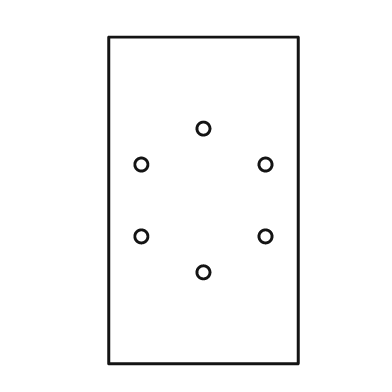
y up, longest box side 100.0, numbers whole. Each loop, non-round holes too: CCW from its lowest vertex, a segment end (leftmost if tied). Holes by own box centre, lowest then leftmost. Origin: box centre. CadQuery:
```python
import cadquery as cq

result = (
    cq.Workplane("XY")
    .moveTo(-29.0, -50.0)
    .lineTo(29.0, -50.0)
    .lineTo(29.0, 50.0)
    .lineTo(-29.0, 50.0)
    .close()
    .moveTo(0.0, -22.0)
    .circle(2.0)
    .moveTo(-19.0, -11.0)
    .circle(2.0)
    .moveTo(19.0, -11.0)
    .circle(2.0)
    .moveTo(-19.0, 11.0)
    .circle(2.0)
    .moveTo(19.0, 11.0)
    .circle(2.0)
    .moveTo(0.0, 22.0)
    .circle(2.0)
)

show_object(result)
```